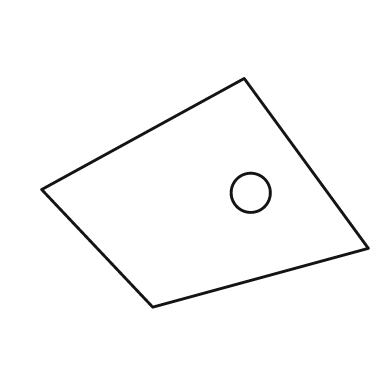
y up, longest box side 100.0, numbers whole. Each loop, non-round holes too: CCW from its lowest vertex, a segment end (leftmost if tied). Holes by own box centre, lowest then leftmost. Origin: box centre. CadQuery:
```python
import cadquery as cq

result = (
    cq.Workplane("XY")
    .moveTo(-16.0, -35.0)
    .lineTo(50.0, -17.0)
    .lineTo(12.0, 35.0)
    .lineTo(-50.0, 1.0)
    .close()
    .moveTo(14.0, 0.0)
    .circle(6.0)
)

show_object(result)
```